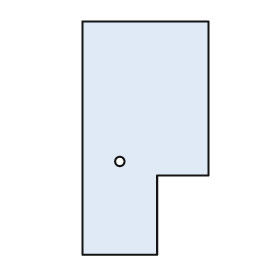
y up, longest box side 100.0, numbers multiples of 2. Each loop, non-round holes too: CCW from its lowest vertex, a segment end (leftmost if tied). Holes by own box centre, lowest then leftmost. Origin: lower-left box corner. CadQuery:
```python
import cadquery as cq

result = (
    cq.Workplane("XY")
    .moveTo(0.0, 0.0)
    .lineTo(32.0, 0.0)
    .lineTo(32.0, 34.0)
    .lineTo(54.0, 34.0)
    .lineTo(54.0, 100.0)
    .lineTo(0.0, 100.0)
    .close()
    .moveTo(16.0, 40.0)
    .circle(2.0)
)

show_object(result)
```